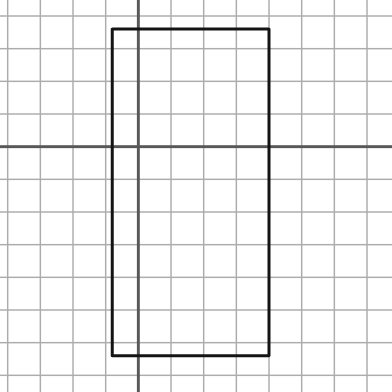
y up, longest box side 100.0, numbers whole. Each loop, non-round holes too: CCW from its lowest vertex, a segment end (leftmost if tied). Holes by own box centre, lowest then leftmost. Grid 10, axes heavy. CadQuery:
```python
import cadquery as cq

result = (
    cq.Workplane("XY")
    .moveTo(-8.0, -64.0)
    .lineTo(40.0, -64.0)
    .lineTo(40.0, 36.0)
    .lineTo(-8.0, 36.0)
    .close()
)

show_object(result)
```